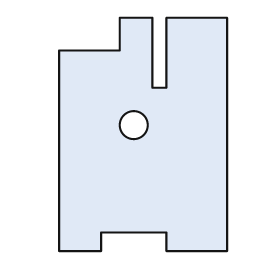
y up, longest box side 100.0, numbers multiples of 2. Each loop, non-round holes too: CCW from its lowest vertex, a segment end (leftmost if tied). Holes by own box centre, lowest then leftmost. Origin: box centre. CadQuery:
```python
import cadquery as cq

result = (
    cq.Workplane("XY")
    .moveTo(-36.0, -50.0)
    .lineTo(-18.0, -50.0)
    .lineTo(-18.0, -42.0)
    .lineTo(10.0, -42.0)
    .lineTo(10.0, -50.0)
    .lineTo(36.0, -50.0)
    .lineTo(36.0, 50.0)
    .lineTo(10.0, 50.0)
    .lineTo(10.0, 20.0)
    .lineTo(4.0, 20.0)
    .lineTo(4.0, 50.0)
    .lineTo(-10.0, 50.0)
    .lineTo(-10.0, 36.0)
    .lineTo(-36.0, 36.0)
    .close()
    .moveTo(-4.0, 4.0)
    .circle(6.0)
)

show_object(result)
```